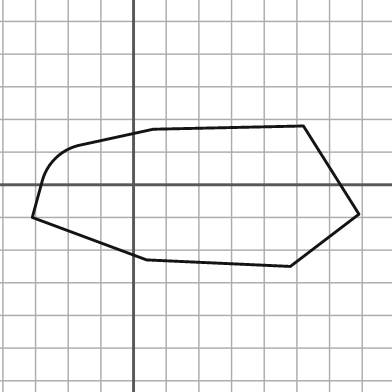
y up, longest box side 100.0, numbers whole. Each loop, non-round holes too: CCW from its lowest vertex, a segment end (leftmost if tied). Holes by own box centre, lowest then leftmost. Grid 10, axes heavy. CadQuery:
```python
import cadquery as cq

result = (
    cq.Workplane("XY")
    .moveTo(48.0, -25.0)
    .lineTo(69.0, -9.0)
    .lineTo(52.0, 18.0)
    .lineTo(6.0, 17.0)
    .lineTo(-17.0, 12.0)
    .threePointArc((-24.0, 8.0), (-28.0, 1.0))
    .lineTo(-31.0, -10.0)
    .lineTo(4.0, -23.0)
    .close()
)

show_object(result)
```